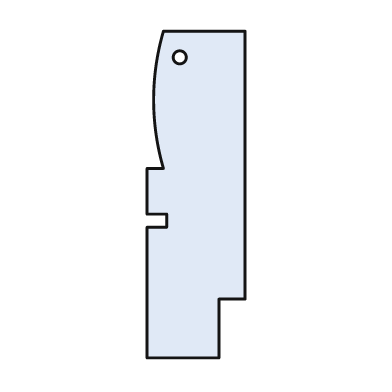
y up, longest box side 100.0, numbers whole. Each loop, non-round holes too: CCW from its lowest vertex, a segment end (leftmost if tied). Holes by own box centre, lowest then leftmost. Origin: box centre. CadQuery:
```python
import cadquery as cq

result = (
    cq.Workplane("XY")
    .moveTo(-15.0, -50.0)
    .lineTo(7.0, -50.0)
    .lineTo(7.0, -32.0)
    .lineTo(15.0, -32.0)
    .lineTo(15.0, 50.0)
    .lineTo(-10.0, 50.0)
    .threePointArc((-13.0, 29.0), (-10.0, 8.0))
    .lineTo(-15.0, 8.0)
    .lineTo(-15.0, -6.0)
    .lineTo(-9.0, -6.0)
    .lineTo(-9.0, -10.0)
    .lineTo(-15.0, -10.0)
    .close()
    .moveTo(-5.0, 42.0)
    .circle(2.0)
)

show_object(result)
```